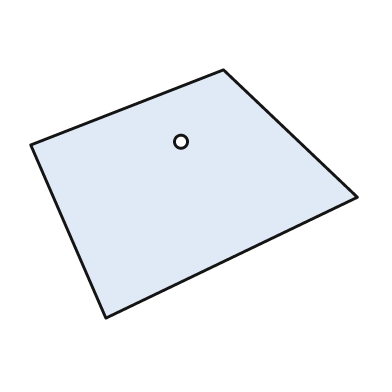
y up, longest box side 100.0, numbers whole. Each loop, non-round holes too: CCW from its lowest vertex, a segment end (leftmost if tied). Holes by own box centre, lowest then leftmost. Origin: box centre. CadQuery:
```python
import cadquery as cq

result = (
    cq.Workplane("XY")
    .moveTo(-27.0, -38.0)
    .lineTo(50.0, -1.0)
    .lineTo(9.0, 38.0)
    .lineTo(-50.0, 15.0)
    .close()
    .moveTo(-4.0, 16.0)
    .circle(2.0)
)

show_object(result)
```